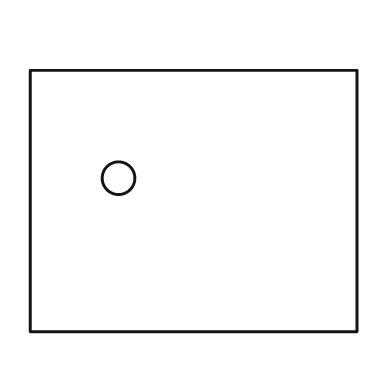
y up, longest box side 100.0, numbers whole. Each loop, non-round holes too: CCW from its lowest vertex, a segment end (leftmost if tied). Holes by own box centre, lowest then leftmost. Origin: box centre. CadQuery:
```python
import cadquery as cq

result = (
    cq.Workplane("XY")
    .moveTo(-50.0, -40.0)
    .lineTo(50.0, -40.0)
    .lineTo(50.0, 40.0)
    .lineTo(-50.0, 40.0)
    .close()
    .moveTo(-23.0, 7.0)
    .circle(5.0)
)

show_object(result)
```